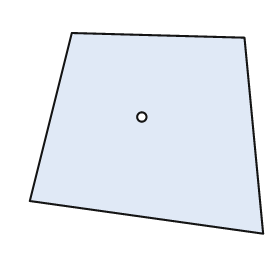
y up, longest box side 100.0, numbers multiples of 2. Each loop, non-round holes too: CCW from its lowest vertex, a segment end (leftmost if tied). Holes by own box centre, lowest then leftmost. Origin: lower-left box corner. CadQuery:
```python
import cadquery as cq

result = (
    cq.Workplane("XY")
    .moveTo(100.0, 0.0)
    .lineTo(92.0, 84.0)
    .lineTo(18.0, 86.0)
    .lineTo(0.0, 14.0)
    .close()
    .moveTo(48.0, 50.0)
    .circle(2.0)
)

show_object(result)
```